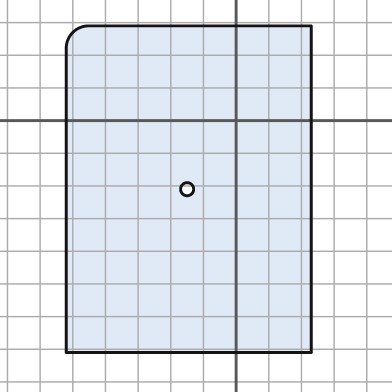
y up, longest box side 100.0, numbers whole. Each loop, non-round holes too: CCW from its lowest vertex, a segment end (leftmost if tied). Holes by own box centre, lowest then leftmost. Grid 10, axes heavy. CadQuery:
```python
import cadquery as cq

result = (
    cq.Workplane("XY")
    .moveTo(-52.0, -71.0)
    .lineTo(23.0, -71.0)
    .lineTo(23.0, 29.0)
    .lineTo(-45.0, 29.0)
    .threePointArc((-50.0, 27.0), (-52.0, 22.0))
    .close()
    .moveTo(-15.0, -21.0)
    .circle(2.0)
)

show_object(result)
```